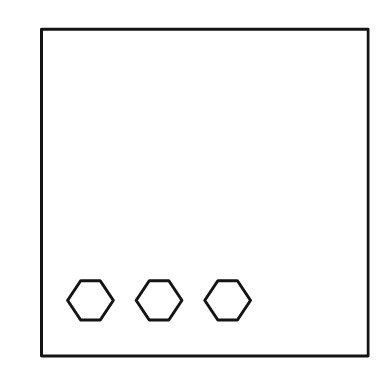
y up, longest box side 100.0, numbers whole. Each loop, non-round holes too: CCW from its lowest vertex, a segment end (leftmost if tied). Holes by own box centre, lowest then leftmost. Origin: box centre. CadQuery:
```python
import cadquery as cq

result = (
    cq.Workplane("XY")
    .moveTo(-50.0, -50.0)
    .lineTo(50.0, -50.0)
    .lineTo(50.0, 50.0)
    .lineTo(-50.0, 50.0)
    .close()
    .moveTo(-38.0, -39.0)
    .lineTo(-32.0, -39.0)
    .lineTo(-28.0, -33.0)
    .lineTo(-32.0, -27.0)
    .lineTo(-38.0, -27.0)
    .lineTo(-42.0, -33.0)
    .close()
    .moveTo(-17.0, -39.0)
    .lineTo(-11.0, -39.0)
    .lineTo(-7.0, -33.0)
    .lineTo(-11.0, -27.0)
    .lineTo(-17.0, -27.0)
    .lineTo(-21.0, -33.0)
    .close()
    .moveTo(4.0, -39.0)
    .lineTo(10.0, -39.0)
    .lineTo(14.0, -33.0)
    .lineTo(10.0, -27.0)
    .lineTo(4.0, -27.0)
    .lineTo(0.0, -33.0)
    .close()
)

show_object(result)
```